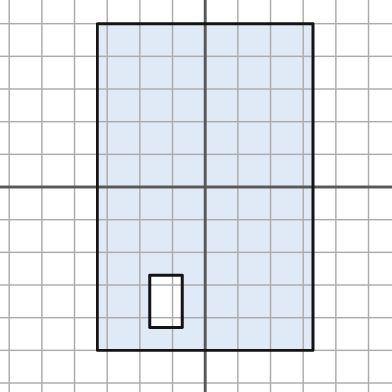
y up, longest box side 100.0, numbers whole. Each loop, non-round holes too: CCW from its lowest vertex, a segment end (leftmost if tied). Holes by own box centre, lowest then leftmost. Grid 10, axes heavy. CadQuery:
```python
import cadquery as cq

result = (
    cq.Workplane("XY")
    .moveTo(-33.0, -50.0)
    .lineTo(33.0, -50.0)
    .lineTo(33.0, 50.0)
    .lineTo(-33.0, 50.0)
    .close()
    .moveTo(-17.0, -43.0)
    .lineTo(-7.0, -43.0)
    .lineTo(-7.0, -27.0)
    .lineTo(-17.0, -27.0)
    .close()
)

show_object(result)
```